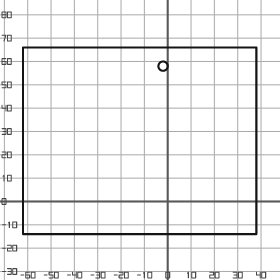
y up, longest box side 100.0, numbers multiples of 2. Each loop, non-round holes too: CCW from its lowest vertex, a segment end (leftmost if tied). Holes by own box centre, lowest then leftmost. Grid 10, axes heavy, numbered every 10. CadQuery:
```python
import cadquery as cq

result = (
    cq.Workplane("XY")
    .moveTo(-62.0, -14.0)
    .lineTo(38.0, -14.0)
    .lineTo(38.0, 66.0)
    .lineTo(-62.0, 66.0)
    .close()
    .moveTo(-2.0, 58.0)
    .circle(2.0)
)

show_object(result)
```